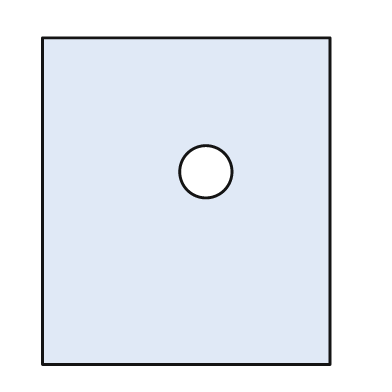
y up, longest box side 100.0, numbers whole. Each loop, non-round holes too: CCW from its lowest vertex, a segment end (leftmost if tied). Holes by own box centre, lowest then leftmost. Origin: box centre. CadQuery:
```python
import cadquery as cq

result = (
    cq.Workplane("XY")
    .moveTo(-44.0, -50.0)
    .lineTo(44.0, -50.0)
    .lineTo(44.0, 50.0)
    .lineTo(-44.0, 50.0)
    .close()
    .moveTo(6.0, 9.0)
    .circle(8.0)
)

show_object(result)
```